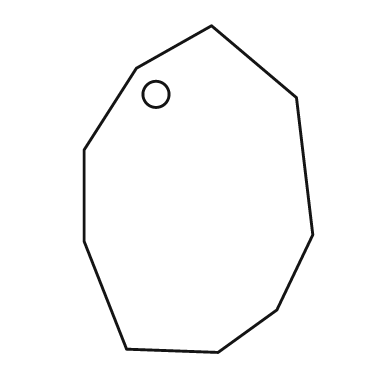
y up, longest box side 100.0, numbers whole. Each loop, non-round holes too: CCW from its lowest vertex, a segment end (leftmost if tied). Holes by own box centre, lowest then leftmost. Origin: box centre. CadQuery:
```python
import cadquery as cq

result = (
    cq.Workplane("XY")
    .moveTo(6.0, -50.0)
    .lineTo(24.0, -37.0)
    .lineTo(35.0, -14.0)
    .lineTo(30.0, 28.0)
    .lineTo(4.0, 50.0)
    .lineTo(-19.0, 37.0)
    .lineTo(-35.0, 12.0)
    .lineTo(-35.0, -16.0)
    .lineTo(-22.0, -49.0)
    .close()
    .moveTo(-13.0, 29.0)
    .circle(4.0)
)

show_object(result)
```